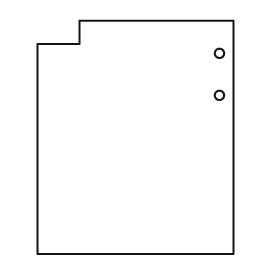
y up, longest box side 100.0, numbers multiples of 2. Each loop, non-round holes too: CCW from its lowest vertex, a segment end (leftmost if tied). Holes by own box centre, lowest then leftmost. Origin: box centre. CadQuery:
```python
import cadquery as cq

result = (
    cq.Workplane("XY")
    .moveTo(-42.0, -50.0)
    .lineTo(42.0, -50.0)
    .lineTo(42.0, 50.0)
    .lineTo(-24.0, 50.0)
    .lineTo(-24.0, 40.0)
    .lineTo(-42.0, 40.0)
    .close()
    .moveTo(36.0, 18.0)
    .circle(2.0)
    .moveTo(36.0, 36.0)
    .circle(2.0)
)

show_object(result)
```